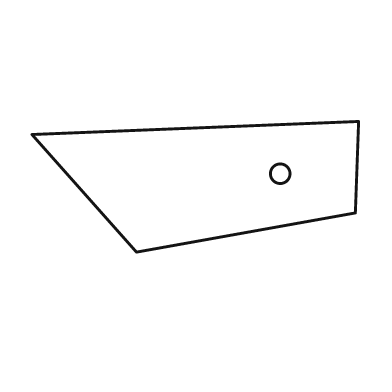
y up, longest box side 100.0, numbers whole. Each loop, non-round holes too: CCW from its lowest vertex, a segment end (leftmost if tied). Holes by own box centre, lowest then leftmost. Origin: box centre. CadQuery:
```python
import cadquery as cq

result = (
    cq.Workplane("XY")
    .moveTo(-18.0, -20.0)
    .lineTo(49.0, -8.0)
    .lineTo(50.0, 20.0)
    .lineTo(-50.0, 16.0)
    .close()
    .moveTo(26.0, 4.0)
    .circle(3.0)
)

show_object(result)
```